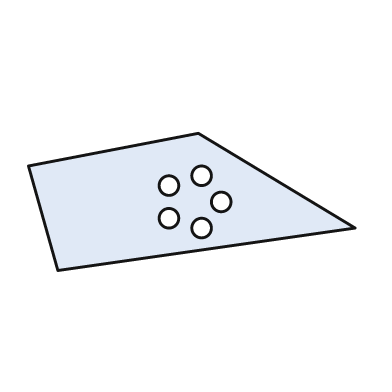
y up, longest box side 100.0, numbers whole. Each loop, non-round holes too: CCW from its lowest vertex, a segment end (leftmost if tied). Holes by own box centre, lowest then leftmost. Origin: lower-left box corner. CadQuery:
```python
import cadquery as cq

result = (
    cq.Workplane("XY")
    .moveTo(9.0, 0.0)
    .lineTo(100.0, 13.0)
    .lineTo(52.0, 42.0)
    .lineTo(0.0, 32.0)
    .close()
    .moveTo(53.0, 13.0)
    .circle(3.0)
    .moveTo(43.0, 16.0)
    .circle(3.0)
    .moveTo(59.0, 21.0)
    .circle(3.0)
    .moveTo(43.0, 26.0)
    .circle(3.0)
    .moveTo(53.0, 29.0)
    .circle(3.0)
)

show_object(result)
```